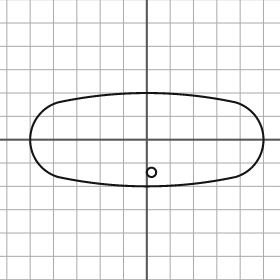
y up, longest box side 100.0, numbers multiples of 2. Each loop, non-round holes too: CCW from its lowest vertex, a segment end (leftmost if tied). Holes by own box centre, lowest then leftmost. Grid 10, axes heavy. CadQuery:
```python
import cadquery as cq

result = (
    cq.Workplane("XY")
    .moveTo(-38.0, -16.0)
    .threePointArc((0.0, -20.0), (38.0, -16.0))
    .threePointArc((50.0, 0.0), (38.0, 16.0))
    .threePointArc((0.0, 20.0), (-38.0, 16.0))
    .threePointArc((-50.0, 0.0), (-38.0, -16.0))
    .close()
    .moveTo(2.0, -14.0)
    .circle(2.0)
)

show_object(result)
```